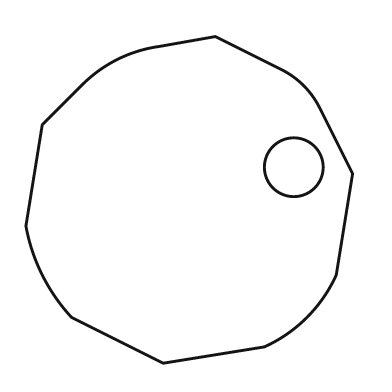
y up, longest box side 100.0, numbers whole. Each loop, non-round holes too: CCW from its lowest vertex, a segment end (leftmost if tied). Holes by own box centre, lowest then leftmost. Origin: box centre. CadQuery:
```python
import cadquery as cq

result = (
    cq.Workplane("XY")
    .moveTo(-8.0, -50.0)
    .lineTo(23.0, -45.0)
    .threePointArc((36.0, -36.0), (45.0, -23.0))
    .lineTo(50.0, 8.0)
    .lineTo(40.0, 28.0)
    .threePointArc((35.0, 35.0), (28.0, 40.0))
    .lineTo(8.0, 50.0)
    .lineTo(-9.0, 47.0)
    .threePointArc((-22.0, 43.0), (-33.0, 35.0))
    .lineTo(-45.0, 23.0)
    .lineTo(-50.0, -8.0)
    .threePointArc((-45.0, -23.0), (-36.0, -36.0))
    .close()
    .moveTo(32.0, 10.0)
    .circle(9.0)
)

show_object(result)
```